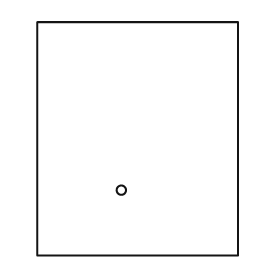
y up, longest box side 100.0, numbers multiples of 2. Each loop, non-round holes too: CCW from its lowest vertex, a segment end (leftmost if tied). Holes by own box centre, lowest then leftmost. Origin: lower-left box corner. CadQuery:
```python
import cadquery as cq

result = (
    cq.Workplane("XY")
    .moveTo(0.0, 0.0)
    .lineTo(86.0, 0.0)
    .lineTo(86.0, 100.0)
    .lineTo(0.0, 100.0)
    .close()
    .moveTo(36.0, 28.0)
    .circle(2.0)
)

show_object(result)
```